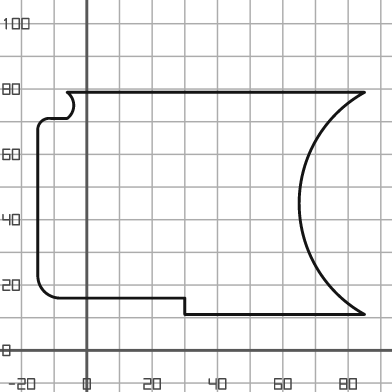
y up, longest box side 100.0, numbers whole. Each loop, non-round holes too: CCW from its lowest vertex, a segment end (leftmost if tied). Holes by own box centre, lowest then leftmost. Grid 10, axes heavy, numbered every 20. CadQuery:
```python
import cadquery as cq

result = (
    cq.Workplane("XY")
    .moveTo(30.0, 11.0)
    .lineTo(85.0, 11.0)
    .threePointArc((65.0, 45.0), (85.0, 79.0))
    .lineTo(-6.0, 79.0)
    .threePointArc((-4.0, 75.0), (-6.0, 71.0))
    .lineTo(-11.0, 71.0)
    .threePointArc((-14.0, 70.0), (-15.0, 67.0))
    .lineTo(-15.0, 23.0)
    .threePointArc((-13.0, 18.0), (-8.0, 16.0))
    .lineTo(30.0, 16.0)
    .close()
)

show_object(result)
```